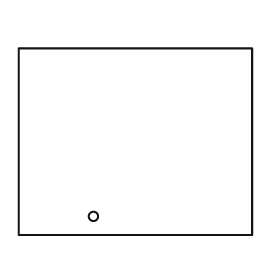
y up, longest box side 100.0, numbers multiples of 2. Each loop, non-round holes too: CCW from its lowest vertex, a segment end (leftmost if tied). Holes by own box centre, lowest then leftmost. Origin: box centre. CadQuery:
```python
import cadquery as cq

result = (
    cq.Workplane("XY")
    .moveTo(-50.0, -40.0)
    .lineTo(50.0, -40.0)
    .lineTo(50.0, 40.0)
    .lineTo(-50.0, 40.0)
    .close()
    .moveTo(-18.0, -32.0)
    .circle(2.0)
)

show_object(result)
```